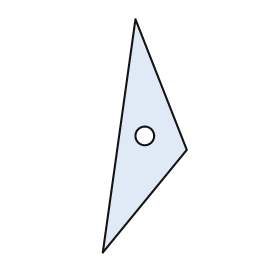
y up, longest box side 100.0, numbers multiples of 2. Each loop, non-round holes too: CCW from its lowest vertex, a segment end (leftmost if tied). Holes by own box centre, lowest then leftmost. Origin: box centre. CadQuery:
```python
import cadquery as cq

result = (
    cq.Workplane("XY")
    .moveTo(-18.0, -50.0)
    .lineTo(18.0, -6.0)
    .lineTo(-4.0, 50.0)
    .close()
    .moveTo(0.0, 0.0)
    .circle(4.0)
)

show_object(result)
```